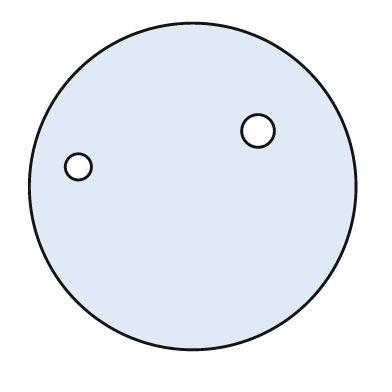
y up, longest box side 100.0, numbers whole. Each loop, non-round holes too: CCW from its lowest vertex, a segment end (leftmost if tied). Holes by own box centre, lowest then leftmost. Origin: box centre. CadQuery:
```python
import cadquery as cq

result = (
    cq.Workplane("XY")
    .moveTo(0.0, 0.0)
    .circle(50.0)
    .moveTo(-35.0, 6.0)
    .circle(4.0)
    .moveTo(20.0, 17.0)
    .circle(5.0)
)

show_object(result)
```